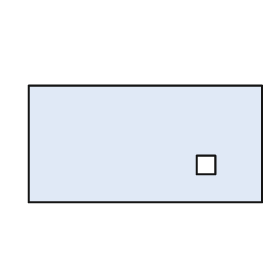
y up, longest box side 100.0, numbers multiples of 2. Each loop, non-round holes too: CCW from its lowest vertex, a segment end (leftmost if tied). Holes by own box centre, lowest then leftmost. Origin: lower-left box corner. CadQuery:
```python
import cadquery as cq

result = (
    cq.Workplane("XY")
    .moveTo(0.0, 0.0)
    .lineTo(100.0, 0.0)
    .lineTo(100.0, 50.0)
    .lineTo(0.0, 50.0)
    .close()
    .moveTo(72.0, 12.0)
    .lineTo(80.0, 12.0)
    .lineTo(80.0, 20.0)
    .lineTo(72.0, 20.0)
    .close()
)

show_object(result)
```